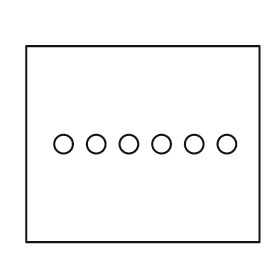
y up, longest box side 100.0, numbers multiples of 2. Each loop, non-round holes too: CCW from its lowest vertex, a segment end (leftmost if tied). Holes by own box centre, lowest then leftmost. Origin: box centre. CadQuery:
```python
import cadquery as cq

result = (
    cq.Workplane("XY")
    .moveTo(-50.0, -42.0)
    .lineTo(50.0, -42.0)
    .lineTo(50.0, 42.0)
    .lineTo(-50.0, 42.0)
    .close()
    .moveTo(-34.0, 0.0)
    .circle(4.0)
    .moveTo(-20.0, 0.0)
    .circle(4.0)
    .moveTo(-6.0, 0.0)
    .circle(4.0)
    .moveTo(8.0, 0.0)
    .circle(4.0)
    .moveTo(22.0, 0.0)
    .circle(4.0)
    .moveTo(36.0, 0.0)
    .circle(4.0)
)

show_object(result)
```